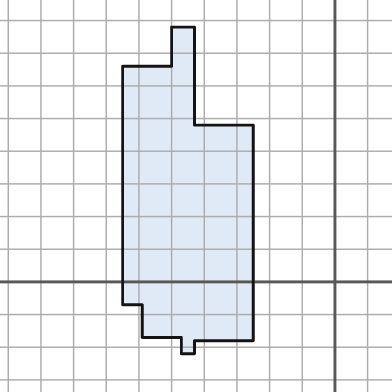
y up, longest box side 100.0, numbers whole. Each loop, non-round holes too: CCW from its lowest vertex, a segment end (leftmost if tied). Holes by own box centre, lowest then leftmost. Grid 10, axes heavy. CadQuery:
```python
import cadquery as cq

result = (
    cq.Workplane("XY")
    .moveTo(-47.0, -22.0)
    .lineTo(-43.0, -22.0)
    .lineTo(-43.0, -18.0)
    .lineTo(-25.0, -18.0)
    .lineTo(-25.0, 48.0)
    .lineTo(-43.0, 48.0)
    .lineTo(-43.0, 78.0)
    .lineTo(-50.0, 78.0)
    .lineTo(-50.0, 66.0)
    .lineTo(-65.0, 66.0)
    .lineTo(-65.0, -7.0)
    .lineTo(-59.0, -7.0)
    .lineTo(-59.0, -17.0)
    .lineTo(-47.0, -17.0)
    .close()
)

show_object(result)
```